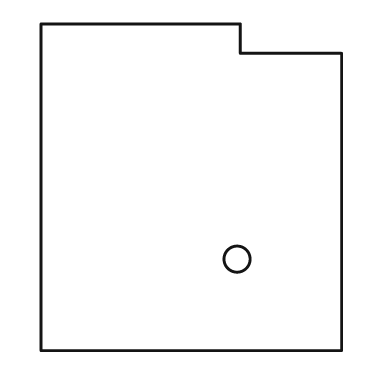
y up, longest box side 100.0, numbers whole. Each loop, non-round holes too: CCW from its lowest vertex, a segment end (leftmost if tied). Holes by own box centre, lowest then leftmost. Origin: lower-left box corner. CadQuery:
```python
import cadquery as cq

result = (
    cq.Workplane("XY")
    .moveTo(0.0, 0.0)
    .lineTo(92.0, 0.0)
    .lineTo(92.0, 91.0)
    .lineTo(61.0, 91.0)
    .lineTo(61.0, 100.0)
    .lineTo(0.0, 100.0)
    .close()
    .moveTo(60.0, 28.0)
    .circle(4.0)
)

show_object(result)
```